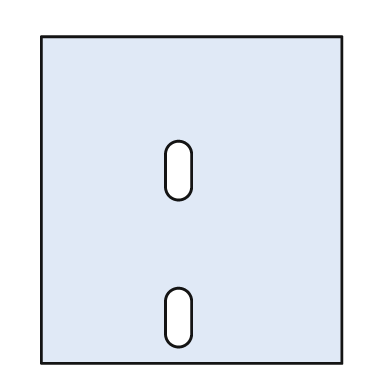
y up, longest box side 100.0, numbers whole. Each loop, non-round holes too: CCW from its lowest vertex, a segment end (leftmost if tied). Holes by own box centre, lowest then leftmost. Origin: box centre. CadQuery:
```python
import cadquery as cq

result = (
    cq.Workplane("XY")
    .moveTo(-46.0, -50.0)
    .lineTo(46.0, -50.0)
    .lineTo(46.0, 50.0)
    .lineTo(-46.0, 50.0)
    .close()
    .moveTo(-8.0, -41.0)
    .threePointArc((-4.0, -45.0), (0.0, -41.0))
    .lineTo(0.0, -31.0)
    .threePointArc((-4.0, -27.0), (-8.0, -31.0))
    .close()
    .moveTo(-8.0, 4.0)
    .threePointArc((-4.0, 0.0), (0.0, 4.0))
    .lineTo(0.0, 14.0)
    .threePointArc((-4.0, 18.0), (-8.0, 14.0))
    .close()
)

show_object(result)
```